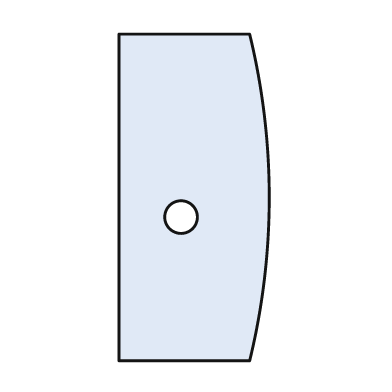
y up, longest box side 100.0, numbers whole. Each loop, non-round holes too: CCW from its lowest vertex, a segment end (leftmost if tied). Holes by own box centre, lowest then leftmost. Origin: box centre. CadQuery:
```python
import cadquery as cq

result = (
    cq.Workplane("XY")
    .moveTo(-23.0, -50.0)
    .lineTo(17.0, -50.0)
    .threePointArc((23.0, 0.0), (17.0, 50.0))
    .lineTo(-23.0, 50.0)
    .close()
    .moveTo(-4.0, -6.0)
    .circle(5.0)
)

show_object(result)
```